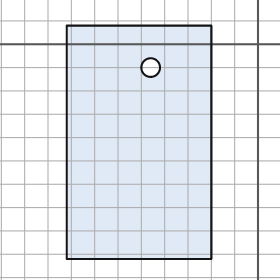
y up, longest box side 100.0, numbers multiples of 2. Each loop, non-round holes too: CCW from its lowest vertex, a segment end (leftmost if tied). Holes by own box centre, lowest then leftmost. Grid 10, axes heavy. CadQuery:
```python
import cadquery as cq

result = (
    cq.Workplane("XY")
    .moveTo(-82.0, -92.0)
    .lineTo(-20.0, -92.0)
    .lineTo(-20.0, 8.0)
    .lineTo(-82.0, 8.0)
    .close()
    .moveTo(-46.0, -10.0)
    .circle(4.0)
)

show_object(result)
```